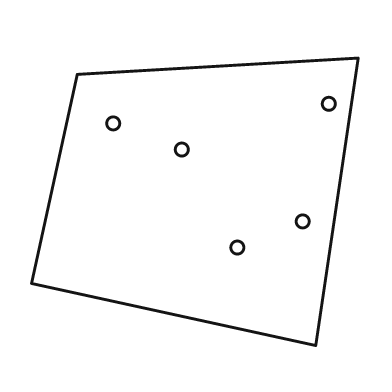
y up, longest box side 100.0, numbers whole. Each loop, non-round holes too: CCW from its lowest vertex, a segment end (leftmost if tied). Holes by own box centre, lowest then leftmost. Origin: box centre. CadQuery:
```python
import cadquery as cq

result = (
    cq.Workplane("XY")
    .moveTo(37.0, -44.0)
    .lineTo(50.0, 44.0)
    .lineTo(-36.0, 39.0)
    .lineTo(-50.0, -25.0)
    .close()
    .moveTo(13.0, -14.0)
    .circle(2.0)
    .moveTo(33.0, -6.0)
    .circle(2.0)
    .moveTo(-4.0, 16.0)
    .circle(2.0)
    .moveTo(-25.0, 24.0)
    .circle(2.0)
    .moveTo(41.0, 30.0)
    .circle(2.0)
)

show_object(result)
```